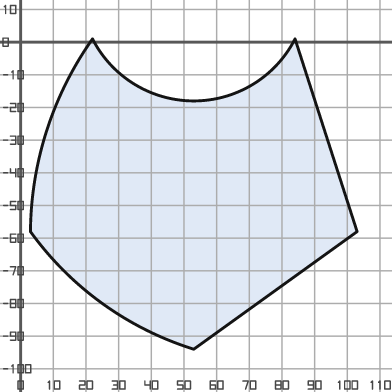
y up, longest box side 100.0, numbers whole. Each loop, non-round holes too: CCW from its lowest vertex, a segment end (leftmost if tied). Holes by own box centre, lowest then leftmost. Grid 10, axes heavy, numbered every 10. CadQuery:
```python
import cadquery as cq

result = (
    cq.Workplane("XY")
    .moveTo(53.0, -94.0)
    .lineTo(103.0, -58.0)
    .lineTo(84.0, 1.0)
    .threePointArc((53.0, -18.0), (22.0, 1.0))
    .threePointArc((8.0, -27.0), (3.0, -58.0))
    .threePointArc((25.0, -80.0), (53.0, -94.0))
    .close()
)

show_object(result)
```